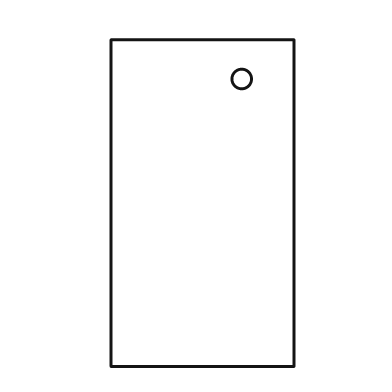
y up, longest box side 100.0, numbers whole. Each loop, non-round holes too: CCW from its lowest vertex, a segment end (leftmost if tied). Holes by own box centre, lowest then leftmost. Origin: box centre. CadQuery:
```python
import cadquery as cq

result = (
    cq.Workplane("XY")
    .moveTo(-28.0, -50.0)
    .lineTo(28.0, -50.0)
    .lineTo(28.0, 50.0)
    .lineTo(-28.0, 50.0)
    .close()
    .moveTo(12.0, 38.0)
    .circle(3.0)
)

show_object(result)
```